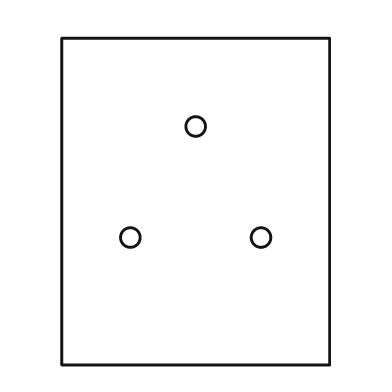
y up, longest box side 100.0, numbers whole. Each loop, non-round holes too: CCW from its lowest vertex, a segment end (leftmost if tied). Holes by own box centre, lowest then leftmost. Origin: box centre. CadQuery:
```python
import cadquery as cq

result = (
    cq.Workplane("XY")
    .moveTo(-41.0, -50.0)
    .lineTo(41.0, -50.0)
    .lineTo(41.0, 50.0)
    .lineTo(-41.0, 50.0)
    .close()
    .moveTo(-20.0, -11.0)
    .circle(3.0)
    .moveTo(20.0, -11.0)
    .circle(3.0)
    .moveTo(0.0, 23.0)
    .circle(3.0)
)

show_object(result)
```